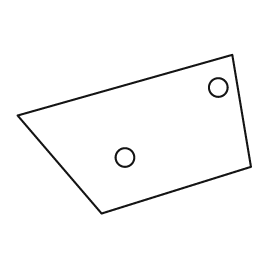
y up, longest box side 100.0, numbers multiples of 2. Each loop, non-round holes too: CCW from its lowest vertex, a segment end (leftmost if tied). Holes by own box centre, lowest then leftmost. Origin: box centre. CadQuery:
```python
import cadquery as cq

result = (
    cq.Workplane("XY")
    .moveTo(-14.0, -34.0)
    .lineTo(50.0, -14.0)
    .lineTo(42.0, 34.0)
    .lineTo(-50.0, 8.0)
    .close()
    .moveTo(-4.0, -10.0)
    .circle(4.0)
    .moveTo(36.0, 20.0)
    .circle(4.0)
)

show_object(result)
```